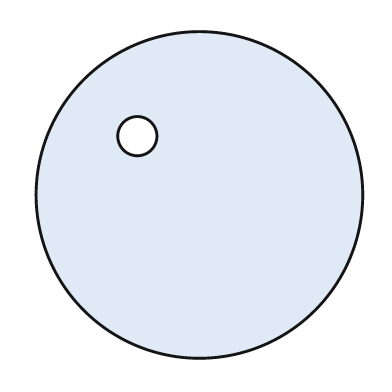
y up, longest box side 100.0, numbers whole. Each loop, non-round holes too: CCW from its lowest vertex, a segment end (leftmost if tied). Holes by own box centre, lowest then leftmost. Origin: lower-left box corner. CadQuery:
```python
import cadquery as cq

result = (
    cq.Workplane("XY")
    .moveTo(50.0, 50.0)
    .circle(50.0)
    .moveTo(31.0, 68.0)
    .circle(6.0)
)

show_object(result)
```